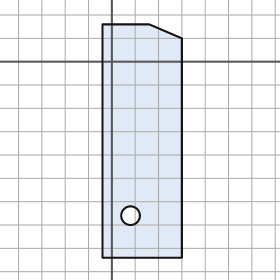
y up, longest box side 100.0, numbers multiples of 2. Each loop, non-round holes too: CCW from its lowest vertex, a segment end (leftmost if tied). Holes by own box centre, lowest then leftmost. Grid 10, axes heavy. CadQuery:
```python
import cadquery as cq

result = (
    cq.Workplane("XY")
    .moveTo(-4.0, -84.0)
    .lineTo(30.0, -84.0)
    .lineTo(30.0, 10.0)
    .lineTo(16.0, 16.0)
    .lineTo(-4.0, 16.0)
    .close()
    .moveTo(8.0, -66.0)
    .circle(4.0)
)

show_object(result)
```